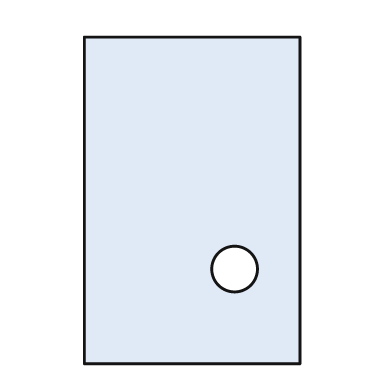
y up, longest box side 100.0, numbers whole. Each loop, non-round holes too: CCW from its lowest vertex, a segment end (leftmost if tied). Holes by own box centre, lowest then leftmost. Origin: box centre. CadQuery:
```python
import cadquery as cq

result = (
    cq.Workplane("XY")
    .moveTo(-33.0, -50.0)
    .lineTo(33.0, -50.0)
    .lineTo(33.0, 50.0)
    .lineTo(-33.0, 50.0)
    .close()
    .moveTo(13.0, -21.0)
    .circle(7.0)
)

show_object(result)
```